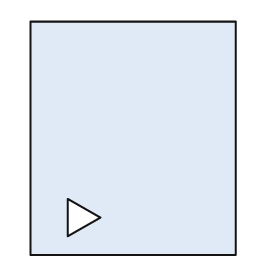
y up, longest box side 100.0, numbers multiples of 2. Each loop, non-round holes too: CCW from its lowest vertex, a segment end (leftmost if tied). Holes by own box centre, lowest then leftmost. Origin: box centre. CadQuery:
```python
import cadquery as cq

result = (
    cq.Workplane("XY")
    .moveTo(-44.0, -50.0)
    .lineTo(44.0, -50.0)
    .lineTo(44.0, 50.0)
    .lineTo(-44.0, 50.0)
    .close()
    .moveTo(-28.0, -42.0)
    .lineTo(-14.0, -34.0)
    .lineTo(-28.0, -26.0)
    .close()
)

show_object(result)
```